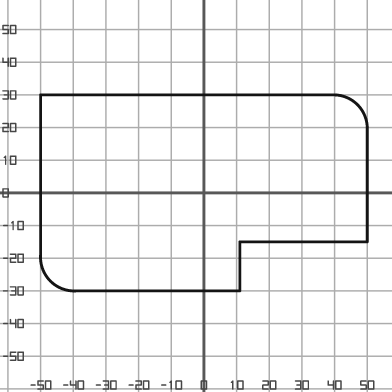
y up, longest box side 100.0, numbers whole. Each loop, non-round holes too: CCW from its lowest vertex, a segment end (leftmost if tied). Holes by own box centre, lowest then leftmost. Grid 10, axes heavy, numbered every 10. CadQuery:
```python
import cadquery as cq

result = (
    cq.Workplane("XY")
    .moveTo(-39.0, -30.0)
    .lineTo(11.0, -30.0)
    .lineTo(11.0, -15.0)
    .lineTo(50.0, -15.0)
    .lineTo(50.0, 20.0)
    .threePointArc((47.0, 27.0), (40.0, 30.0))
    .lineTo(-50.0, 30.0)
    .lineTo(-50.0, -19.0)
    .threePointArc((-47.0, -27.0), (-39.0, -30.0))
    .close()
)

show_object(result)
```